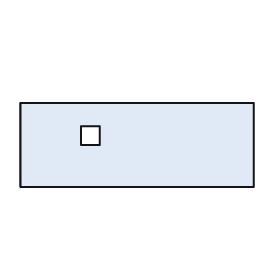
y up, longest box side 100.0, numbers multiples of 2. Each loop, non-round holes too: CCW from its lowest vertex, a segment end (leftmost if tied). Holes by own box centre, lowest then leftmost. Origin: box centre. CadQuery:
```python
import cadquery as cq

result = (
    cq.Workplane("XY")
    .moveTo(-50.0, -18.0)
    .lineTo(50.0, -18.0)
    .lineTo(50.0, 18.0)
    .lineTo(-50.0, 18.0)
    .close()
    .moveTo(-24.0, 0.0)
    .lineTo(-16.0, 0.0)
    .lineTo(-16.0, 8.0)
    .lineTo(-24.0, 8.0)
    .close()
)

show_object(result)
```